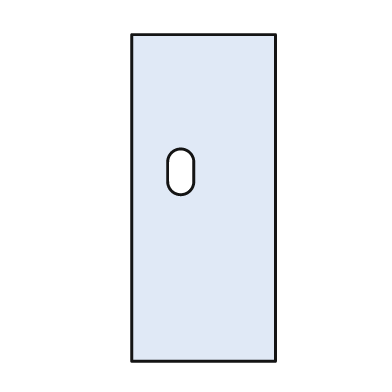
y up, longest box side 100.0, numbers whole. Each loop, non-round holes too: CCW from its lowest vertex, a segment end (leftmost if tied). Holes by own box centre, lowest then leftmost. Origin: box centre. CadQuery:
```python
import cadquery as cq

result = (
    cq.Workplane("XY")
    .moveTo(-22.0, -50.0)
    .lineTo(22.0, -50.0)
    .lineTo(22.0, 50.0)
    .lineTo(-22.0, 50.0)
    .close()
    .moveTo(-11.0, 5.0)
    .threePointArc((-7.0, 1.0), (-3.0, 5.0))
    .lineTo(-3.0, 11.0)
    .threePointArc((-7.0, 15.0), (-11.0, 11.0))
    .close()
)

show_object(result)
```